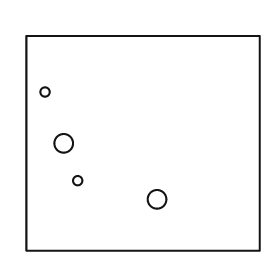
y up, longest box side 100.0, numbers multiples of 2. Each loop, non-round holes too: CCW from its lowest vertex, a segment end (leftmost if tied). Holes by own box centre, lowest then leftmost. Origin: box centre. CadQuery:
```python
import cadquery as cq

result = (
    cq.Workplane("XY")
    .moveTo(-50.0, -46.0)
    .lineTo(50.0, -46.0)
    .lineTo(50.0, 46.0)
    .lineTo(-50.0, 46.0)
    .close()
    .moveTo(6.0, -24.0)
    .circle(4.0)
    .moveTo(-28.0, -16.0)
    .circle(2.0)
    .moveTo(-34.0, 0.0)
    .circle(4.0)
    .moveTo(-42.0, 22.0)
    .circle(2.0)
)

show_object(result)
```